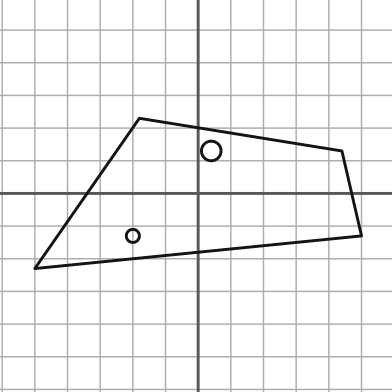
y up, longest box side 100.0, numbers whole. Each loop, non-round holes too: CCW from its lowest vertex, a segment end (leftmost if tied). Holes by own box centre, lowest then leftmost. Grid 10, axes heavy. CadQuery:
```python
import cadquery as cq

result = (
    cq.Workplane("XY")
    .moveTo(-50.0, -23.0)
    .lineTo(50.0, -13.0)
    .lineTo(44.0, 13.0)
    .lineTo(-18.0, 23.0)
    .close()
    .moveTo(-20.0, -13.0)
    .circle(2.0)
    .moveTo(4.0, 13.0)
    .circle(3.0)
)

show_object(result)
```